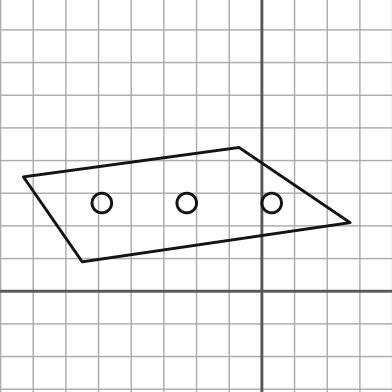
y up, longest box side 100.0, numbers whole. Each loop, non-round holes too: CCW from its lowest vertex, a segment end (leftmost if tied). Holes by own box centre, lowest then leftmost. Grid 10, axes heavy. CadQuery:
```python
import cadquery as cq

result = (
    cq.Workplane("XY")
    .moveTo(-55.0, 9.0)
    .lineTo(27.0, 21.0)
    .lineTo(-7.0, 44.0)
    .lineTo(-73.0, 35.0)
    .close()
    .moveTo(-49.0, 27.0)
    .circle(3.0)
    .moveTo(-23.0, 27.0)
    .circle(3.0)
    .moveTo(3.0, 27.0)
    .circle(3.0)
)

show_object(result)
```